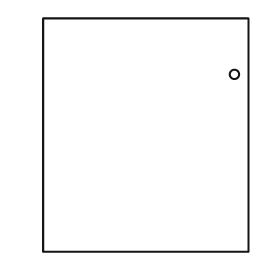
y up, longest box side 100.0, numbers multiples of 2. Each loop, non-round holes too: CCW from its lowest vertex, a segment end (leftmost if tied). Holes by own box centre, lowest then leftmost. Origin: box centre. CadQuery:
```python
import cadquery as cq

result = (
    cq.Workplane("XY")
    .moveTo(-44.0, -50.0)
    .lineTo(44.0, -50.0)
    .lineTo(44.0, 50.0)
    .lineTo(-44.0, 50.0)
    .close()
    .moveTo(38.0, 26.0)
    .circle(2.0)
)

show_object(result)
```